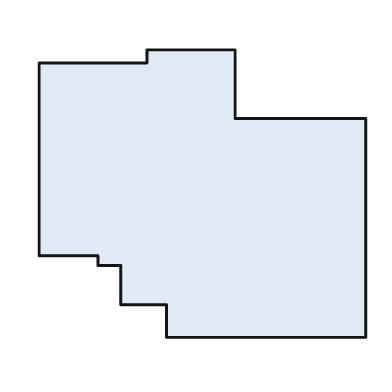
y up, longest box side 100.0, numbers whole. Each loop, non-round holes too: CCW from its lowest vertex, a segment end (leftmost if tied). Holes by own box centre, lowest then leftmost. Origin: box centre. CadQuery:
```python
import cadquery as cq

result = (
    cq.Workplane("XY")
    .moveTo(-11.0, -44.0)
    .lineTo(50.0, -44.0)
    .lineTo(50.0, 23.0)
    .lineTo(10.0, 23.0)
    .lineTo(10.0, 44.0)
    .lineTo(-17.0, 44.0)
    .lineTo(-17.0, 40.0)
    .lineTo(-50.0, 40.0)
    .lineTo(-50.0, -19.0)
    .lineTo(-32.0, -19.0)
    .lineTo(-32.0, -22.0)
    .lineTo(-25.0, -22.0)
    .lineTo(-25.0, -34.0)
    .lineTo(-11.0, -34.0)
    .close()
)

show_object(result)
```